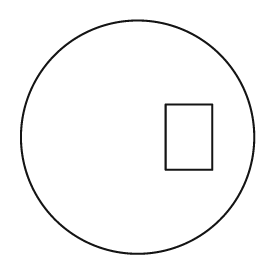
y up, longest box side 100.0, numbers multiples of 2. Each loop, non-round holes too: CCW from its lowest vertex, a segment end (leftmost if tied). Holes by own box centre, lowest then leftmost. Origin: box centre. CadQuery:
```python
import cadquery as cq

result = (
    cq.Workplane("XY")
    .moveTo(0.0, 0.0)
    .circle(50.0)
    .moveTo(12.0, -14.0)
    .lineTo(32.0, -14.0)
    .lineTo(32.0, 14.0)
    .lineTo(12.0, 14.0)
    .close()
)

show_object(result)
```